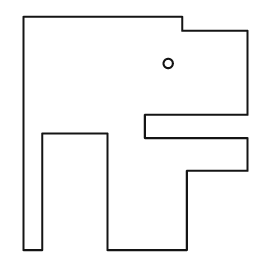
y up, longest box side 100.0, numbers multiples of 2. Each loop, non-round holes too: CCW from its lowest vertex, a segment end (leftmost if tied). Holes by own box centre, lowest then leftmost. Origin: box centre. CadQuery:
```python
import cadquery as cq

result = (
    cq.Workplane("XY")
    .moveTo(-48.0, -50.0)
    .lineTo(-40.0, -50.0)
    .lineTo(-40.0, 0.0)
    .lineTo(-12.0, 0.0)
    .lineTo(-12.0, -50.0)
    .lineTo(22.0, -50.0)
    .lineTo(22.0, -16.0)
    .lineTo(48.0, -16.0)
    .lineTo(48.0, -2.0)
    .lineTo(4.0, -2.0)
    .lineTo(4.0, 8.0)
    .lineTo(48.0, 8.0)
    .lineTo(48.0, 44.0)
    .lineTo(20.0, 44.0)
    .lineTo(20.0, 50.0)
    .lineTo(-48.0, 50.0)
    .close()
    .moveTo(14.0, 30.0)
    .circle(2.0)
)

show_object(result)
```